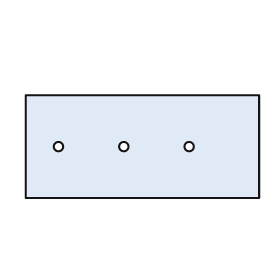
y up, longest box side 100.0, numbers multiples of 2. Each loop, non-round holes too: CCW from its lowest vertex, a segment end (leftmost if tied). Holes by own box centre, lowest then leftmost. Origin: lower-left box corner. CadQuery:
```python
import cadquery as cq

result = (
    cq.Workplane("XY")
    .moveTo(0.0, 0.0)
    .lineTo(100.0, 0.0)
    .lineTo(100.0, 44.0)
    .lineTo(0.0, 44.0)
    .close()
    .moveTo(14.0, 22.0)
    .circle(2.0)
    .moveTo(42.0, 22.0)
    .circle(2.0)
    .moveTo(70.0, 22.0)
    .circle(2.0)
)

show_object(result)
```